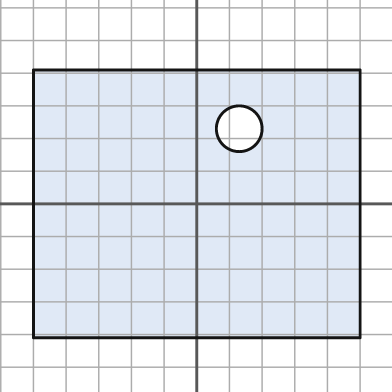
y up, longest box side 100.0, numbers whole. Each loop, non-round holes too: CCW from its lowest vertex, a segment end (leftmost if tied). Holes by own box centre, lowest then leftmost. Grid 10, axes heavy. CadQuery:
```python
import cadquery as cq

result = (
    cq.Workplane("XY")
    .moveTo(-50.0, -41.0)
    .lineTo(50.0, -41.0)
    .lineTo(50.0, 41.0)
    .lineTo(-50.0, 41.0)
    .close()
    .moveTo(13.0, 23.0)
    .circle(7.0)
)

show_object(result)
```